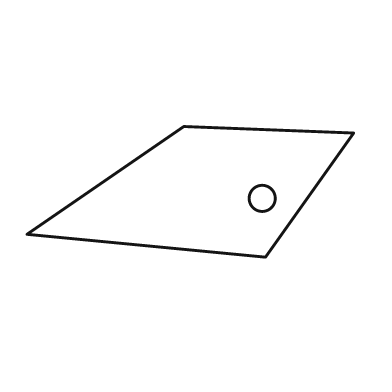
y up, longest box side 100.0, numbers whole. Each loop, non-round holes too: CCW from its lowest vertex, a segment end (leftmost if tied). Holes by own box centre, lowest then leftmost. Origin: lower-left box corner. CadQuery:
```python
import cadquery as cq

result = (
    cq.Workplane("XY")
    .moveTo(73.0, 0.0)
    .lineTo(100.0, 38.0)
    .lineTo(48.0, 40.0)
    .lineTo(0.0, 7.0)
    .close()
    .moveTo(72.0, 18.0)
    .circle(4.0)
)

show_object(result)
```